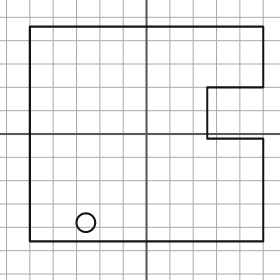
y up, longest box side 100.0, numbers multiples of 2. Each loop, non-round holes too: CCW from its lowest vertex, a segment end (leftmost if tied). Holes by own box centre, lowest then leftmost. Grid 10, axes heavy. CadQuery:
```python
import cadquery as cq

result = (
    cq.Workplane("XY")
    .moveTo(-50.0, -46.0)
    .lineTo(50.0, -46.0)
    .lineTo(50.0, -2.0)
    .lineTo(26.0, -2.0)
    .lineTo(26.0, 20.0)
    .lineTo(50.0, 20.0)
    .lineTo(50.0, 46.0)
    .lineTo(-50.0, 46.0)
    .close()
    .moveTo(-26.0, -38.0)
    .circle(4.0)
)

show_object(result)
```